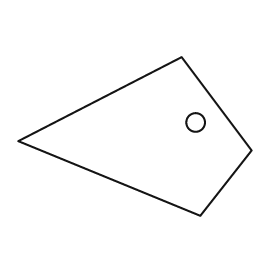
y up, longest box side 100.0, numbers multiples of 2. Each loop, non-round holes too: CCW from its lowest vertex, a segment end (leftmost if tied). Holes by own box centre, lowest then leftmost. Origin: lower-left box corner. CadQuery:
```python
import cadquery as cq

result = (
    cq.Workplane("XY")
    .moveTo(78.0, 0.0)
    .lineTo(100.0, 28.0)
    .lineTo(70.0, 68.0)
    .lineTo(0.0, 32.0)
    .close()
    .moveTo(76.0, 40.0)
    .circle(4.0)
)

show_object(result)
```